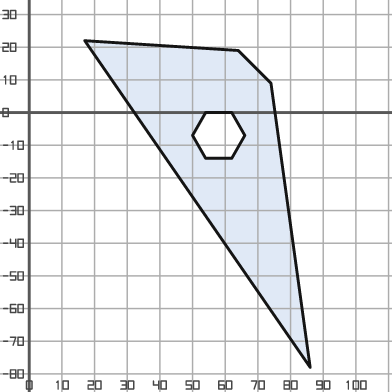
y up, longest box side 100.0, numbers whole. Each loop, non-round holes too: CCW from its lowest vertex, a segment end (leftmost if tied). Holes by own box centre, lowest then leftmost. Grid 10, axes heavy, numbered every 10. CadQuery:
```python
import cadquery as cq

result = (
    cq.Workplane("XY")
    .moveTo(86.0, -78.0)
    .lineTo(74.0, 9.0)
    .lineTo(64.0, 19.0)
    .lineTo(17.0, 22.0)
    .close()
    .moveTo(54.0, -14.0)
    .lineTo(62.0, -14.0)
    .lineTo(66.0, -7.0)
    .lineTo(62.0, 0.0)
    .lineTo(54.0, 0.0)
    .lineTo(50.0, -7.0)
    .close()
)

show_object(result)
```